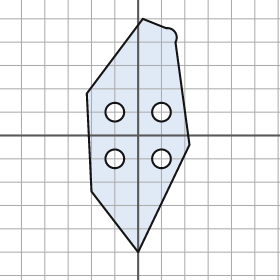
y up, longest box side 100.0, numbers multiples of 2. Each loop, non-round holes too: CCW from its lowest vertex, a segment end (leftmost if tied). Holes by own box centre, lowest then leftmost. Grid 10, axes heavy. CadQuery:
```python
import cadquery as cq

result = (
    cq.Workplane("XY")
    .moveTo(0.0, -50.0)
    .lineTo(22.0, -4.0)
    .lineTo(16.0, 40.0)
    .threePointArc((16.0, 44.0), (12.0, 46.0))
    .lineTo(2.0, 50.0)
    .lineTo(-22.0, 18.0)
    .lineTo(-20.0, -24.0)
    .close()
    .moveTo(-10.0, -10.0)
    .circle(4.0)
    .moveTo(10.0, -10.0)
    .circle(4.0)
    .moveTo(-10.0, 10.0)
    .circle(4.0)
    .moveTo(10.0, 10.0)
    .circle(4.0)
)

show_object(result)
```